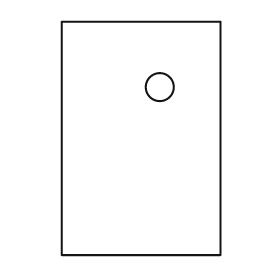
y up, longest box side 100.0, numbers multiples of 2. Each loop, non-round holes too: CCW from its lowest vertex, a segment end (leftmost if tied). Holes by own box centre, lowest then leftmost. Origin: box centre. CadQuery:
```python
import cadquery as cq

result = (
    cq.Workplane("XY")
    .moveTo(-34.0, -50.0)
    .lineTo(34.0, -50.0)
    .lineTo(34.0, 50.0)
    .lineTo(-34.0, 50.0)
    .close()
    .moveTo(8.0, 22.0)
    .circle(6.0)
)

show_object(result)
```